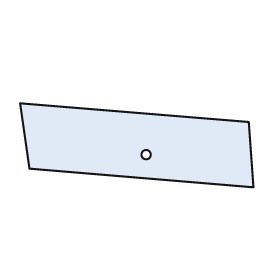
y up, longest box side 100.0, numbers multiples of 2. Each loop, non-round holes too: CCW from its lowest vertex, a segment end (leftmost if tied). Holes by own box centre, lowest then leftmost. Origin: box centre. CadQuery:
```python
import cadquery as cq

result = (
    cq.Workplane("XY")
    .moveTo(50.0, -18.0)
    .lineTo(48.0, 10.0)
    .lineTo(-50.0, 18.0)
    .lineTo(-46.0, -10.0)
    .close()
    .moveTo(4.0, -4.0)
    .circle(2.0)
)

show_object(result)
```